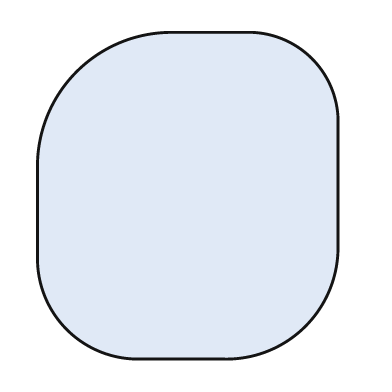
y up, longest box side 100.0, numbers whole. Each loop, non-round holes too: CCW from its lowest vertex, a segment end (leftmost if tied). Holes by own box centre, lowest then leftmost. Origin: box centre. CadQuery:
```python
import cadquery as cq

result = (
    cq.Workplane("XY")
    .moveTo(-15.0, -50.0)
    .lineTo(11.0, -50.0)
    .threePointArc((36.0, -40.0), (46.0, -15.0))
    .lineTo(46.0, 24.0)
    .threePointArc((38.0, 42.0), (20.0, 50.0))
    .lineTo(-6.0, 50.0)
    .threePointArc((-34.0, 38.0), (-46.0, 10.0))
    .lineTo(-46.0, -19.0)
    .threePointArc((-37.0, -41.0), (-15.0, -50.0))
    .close()
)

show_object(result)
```